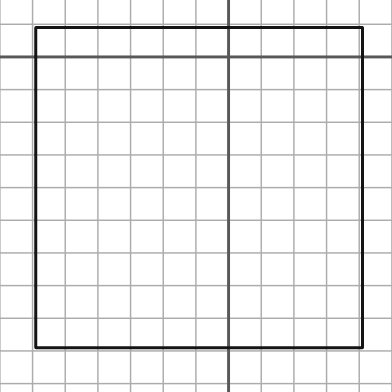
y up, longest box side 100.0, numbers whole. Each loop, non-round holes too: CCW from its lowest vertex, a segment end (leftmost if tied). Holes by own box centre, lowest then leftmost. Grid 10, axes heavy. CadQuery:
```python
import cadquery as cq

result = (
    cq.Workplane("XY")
    .moveTo(-59.0, -89.0)
    .lineTo(41.0, -89.0)
    .lineTo(41.0, 9.0)
    .lineTo(-59.0, 9.0)
    .close()
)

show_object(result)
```